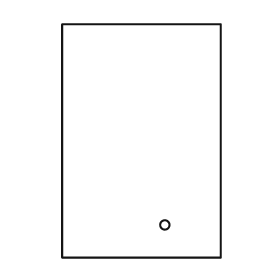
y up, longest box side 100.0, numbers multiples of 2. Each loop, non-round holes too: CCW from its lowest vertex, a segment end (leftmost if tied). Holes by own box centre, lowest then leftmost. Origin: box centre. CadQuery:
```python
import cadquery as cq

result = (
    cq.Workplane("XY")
    .moveTo(-34.0, -50.0)
    .lineTo(34.0, -50.0)
    .lineTo(34.0, 50.0)
    .lineTo(-34.0, 50.0)
    .close()
    .moveTo(10.0, -36.0)
    .circle(2.0)
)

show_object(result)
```